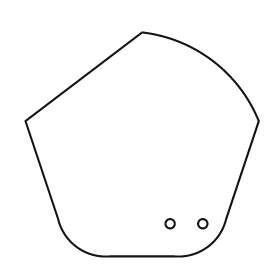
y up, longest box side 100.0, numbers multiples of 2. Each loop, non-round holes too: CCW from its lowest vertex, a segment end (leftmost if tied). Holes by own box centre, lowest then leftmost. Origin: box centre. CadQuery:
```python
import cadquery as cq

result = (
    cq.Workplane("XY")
    .moveTo(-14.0, -48.0)
    .lineTo(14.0, -48.0)
    .threePointArc((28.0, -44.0), (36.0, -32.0))
    .lineTo(50.0, 10.0)
    .threePointArc((30.0, 36.0), (0.0, 48.0))
    .lineTo(-50.0, 10.0)
    .lineTo(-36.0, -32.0)
    .threePointArc((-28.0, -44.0), (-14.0, -48.0))
    .close()
    .moveTo(12.0, -34.0)
    .circle(2.0)
    .moveTo(26.0, -34.0)
    .circle(2.0)
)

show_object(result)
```